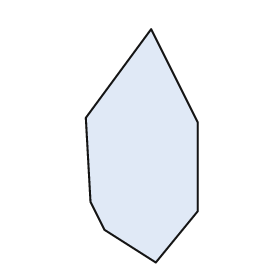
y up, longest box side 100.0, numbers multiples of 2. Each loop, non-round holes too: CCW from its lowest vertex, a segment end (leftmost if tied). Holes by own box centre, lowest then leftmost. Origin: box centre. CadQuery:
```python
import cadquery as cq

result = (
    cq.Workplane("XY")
    .moveTo(6.0, -50.0)
    .lineTo(24.0, -28.0)
    .lineTo(24.0, 10.0)
    .lineTo(4.0, 50.0)
    .lineTo(-24.0, 12.0)
    .lineTo(-22.0, -24.0)
    .lineTo(-16.0, -36.0)
    .close()
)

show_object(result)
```